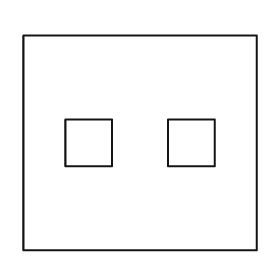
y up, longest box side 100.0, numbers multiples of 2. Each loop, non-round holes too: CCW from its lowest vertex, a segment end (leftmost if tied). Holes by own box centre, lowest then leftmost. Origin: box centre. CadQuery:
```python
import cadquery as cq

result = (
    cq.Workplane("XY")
    .moveTo(-50.0, -46.0)
    .lineTo(50.0, -46.0)
    .lineTo(50.0, 46.0)
    .lineTo(-50.0, 46.0)
    .close()
    .moveTo(-32.0, -10.0)
    .lineTo(-12.0, -10.0)
    .lineTo(-12.0, 10.0)
    .lineTo(-32.0, 10.0)
    .close()
    .moveTo(12.0, -10.0)
    .lineTo(32.0, -10.0)
    .lineTo(32.0, 10.0)
    .lineTo(12.0, 10.0)
    .close()
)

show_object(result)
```